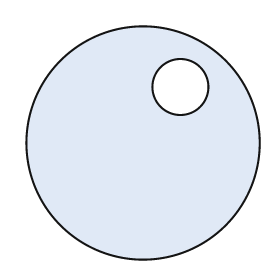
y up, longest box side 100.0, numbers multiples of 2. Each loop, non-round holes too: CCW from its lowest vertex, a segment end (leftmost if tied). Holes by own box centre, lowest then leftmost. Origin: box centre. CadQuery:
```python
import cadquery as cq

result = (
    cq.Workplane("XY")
    .moveTo(0.0, 0.0)
    .circle(50.0)
    .moveTo(16.0, 24.0)
    .circle(12.0)
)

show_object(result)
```